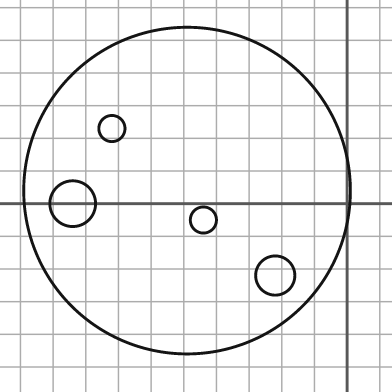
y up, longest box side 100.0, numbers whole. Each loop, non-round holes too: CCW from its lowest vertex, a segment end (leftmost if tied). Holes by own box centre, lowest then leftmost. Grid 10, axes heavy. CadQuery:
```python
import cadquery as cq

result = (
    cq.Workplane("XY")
    .moveTo(-49.0, 4.0)
    .circle(50.0)
    .moveTo(-22.0, -22.0)
    .circle(6.0)
    .moveTo(-44.0, -5.0)
    .circle(4.0)
    .moveTo(-84.0, 0.0)
    .circle(7.0)
    .moveTo(-72.0, 23.0)
    .circle(4.0)
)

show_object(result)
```